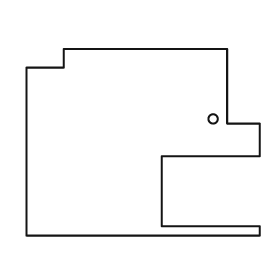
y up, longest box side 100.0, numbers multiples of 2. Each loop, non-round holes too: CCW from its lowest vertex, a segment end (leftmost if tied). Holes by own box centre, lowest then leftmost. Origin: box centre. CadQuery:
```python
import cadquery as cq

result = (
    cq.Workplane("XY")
    .moveTo(-50.0, -40.0)
    .lineTo(50.0, -40.0)
    .lineTo(50.0, -36.0)
    .lineTo(8.0, -36.0)
    .lineTo(8.0, -6.0)
    .lineTo(50.0, -6.0)
    .lineTo(50.0, 8.0)
    .lineTo(36.0, 8.0)
    .lineTo(36.0, 40.0)
    .lineTo(-34.0, 40.0)
    .lineTo(-34.0, 32.0)
    .lineTo(-50.0, 32.0)
    .close()
    .moveTo(30.0, 10.0)
    .circle(2.0)
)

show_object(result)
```